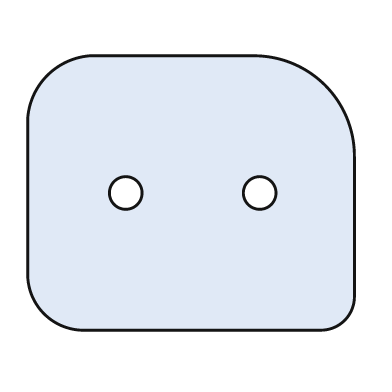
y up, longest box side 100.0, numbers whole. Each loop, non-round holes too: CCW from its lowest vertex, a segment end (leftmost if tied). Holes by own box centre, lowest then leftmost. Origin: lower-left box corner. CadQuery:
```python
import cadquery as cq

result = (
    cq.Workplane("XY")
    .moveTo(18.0, 0.0)
    .lineTo(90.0, 0.0)
    .threePointArc((97.0, 3.0), (100.0, 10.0))
    .lineTo(100.0, 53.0)
    .threePointArc((91.0, 75.0), (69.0, 84.0))
    .lineTo(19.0, 84.0)
    .threePointArc((6.0, 78.0), (0.0, 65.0))
    .lineTo(0.0, 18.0)
    .threePointArc((5.0, 5.0), (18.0, 0.0))
    .close()
    .moveTo(30.0, 42.0)
    .circle(5.0)
    .moveTo(71.0, 42.0)
    .circle(5.0)
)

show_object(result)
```